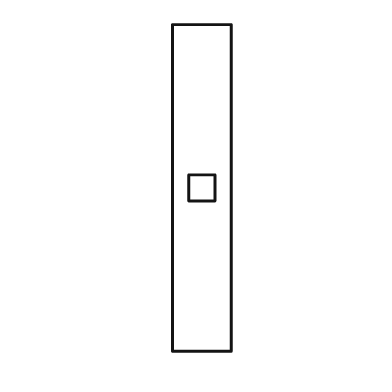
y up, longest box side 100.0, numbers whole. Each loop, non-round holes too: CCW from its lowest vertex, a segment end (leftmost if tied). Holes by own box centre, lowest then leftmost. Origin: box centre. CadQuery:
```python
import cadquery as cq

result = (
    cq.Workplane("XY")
    .moveTo(-9.0, -50.0)
    .lineTo(9.0, -50.0)
    .lineTo(9.0, 50.0)
    .lineTo(-9.0, 50.0)
    .close()
    .moveTo(-4.0, -4.0)
    .lineTo(4.0, -4.0)
    .lineTo(4.0, 4.0)
    .lineTo(-4.0, 4.0)
    .close()
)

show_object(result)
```